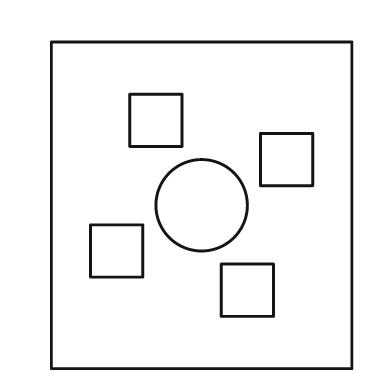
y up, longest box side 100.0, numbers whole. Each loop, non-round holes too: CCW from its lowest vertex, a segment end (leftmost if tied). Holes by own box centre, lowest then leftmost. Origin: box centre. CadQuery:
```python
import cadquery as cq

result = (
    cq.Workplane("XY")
    .moveTo(-46.0, -50.0)
    .lineTo(46.0, -50.0)
    .lineTo(46.0, 50.0)
    .lineTo(-46.0, 50.0)
    .close()
    .moveTo(6.0, -34.0)
    .lineTo(22.0, -34.0)
    .lineTo(22.0, -18.0)
    .lineTo(6.0, -18.0)
    .close()
    .moveTo(-34.0, -22.0)
    .lineTo(-18.0, -22.0)
    .lineTo(-18.0, -6.0)
    .lineTo(-34.0, -6.0)
    .close()
    .moveTo(0.0, 0.0)
    .circle(14.0)
    .moveTo(18.0, 6.0)
    .lineTo(34.0, 6.0)
    .lineTo(34.0, 22.0)
    .lineTo(18.0, 22.0)
    .close()
    .moveTo(-22.0, 18.0)
    .lineTo(-6.0, 18.0)
    .lineTo(-6.0, 34.0)
    .lineTo(-22.0, 34.0)
    .close()
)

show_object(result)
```